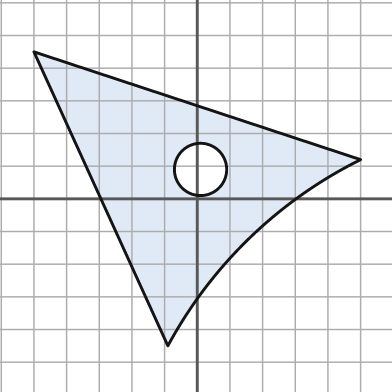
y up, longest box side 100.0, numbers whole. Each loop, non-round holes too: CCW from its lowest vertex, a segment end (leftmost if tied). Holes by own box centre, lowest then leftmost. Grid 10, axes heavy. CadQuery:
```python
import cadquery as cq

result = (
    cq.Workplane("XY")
    .moveTo(-9.0, -45.0)
    .threePointArc((16.0, -12.0), (50.0, 12.0))
    .lineTo(-50.0, 45.0)
    .close()
    .moveTo(1.0, 9.0)
    .circle(8.0)
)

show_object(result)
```